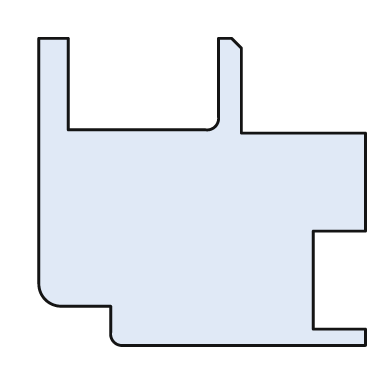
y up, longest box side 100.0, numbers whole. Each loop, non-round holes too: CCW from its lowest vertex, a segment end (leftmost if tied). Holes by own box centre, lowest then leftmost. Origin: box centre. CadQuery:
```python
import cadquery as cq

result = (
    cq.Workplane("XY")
    .moveTo(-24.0, -47.0)
    .lineTo(50.0, -47.0)
    .lineTo(50.0, -42.0)
    .lineTo(34.0, -42.0)
    .lineTo(34.0, -12.0)
    .lineTo(50.0, -12.0)
    .lineTo(50.0, 18.0)
    .lineTo(12.0, 18.0)
    .lineTo(12.0, 44.0)
    .lineTo(9.0, 47.0)
    .lineTo(5.0, 47.0)
    .lineTo(5.0, 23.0)
    .threePointArc((4.0, 20.0), (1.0, 19.0))
    .lineTo(-41.0, 19.0)
    .lineTo(-41.0, 47.0)
    .lineTo(-50.0, 47.0)
    .lineTo(-50.0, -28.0)
    .threePointArc((-48.0, -33.0), (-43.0, -35.0))
    .lineTo(-28.0, -35.0)
    .lineTo(-28.0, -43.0)
    .threePointArc((-27.0, -46.0), (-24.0, -47.0))
    .close()
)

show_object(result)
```